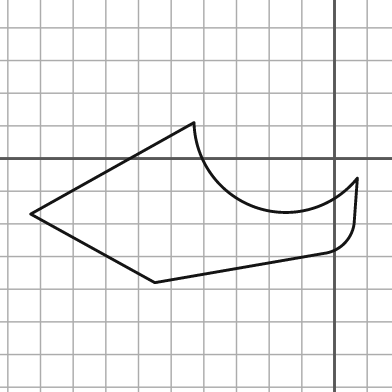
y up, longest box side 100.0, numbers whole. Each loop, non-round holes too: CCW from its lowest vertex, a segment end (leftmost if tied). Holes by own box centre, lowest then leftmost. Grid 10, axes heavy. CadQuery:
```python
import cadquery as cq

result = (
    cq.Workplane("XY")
    .moveTo(-55.0, -38.0)
    .lineTo(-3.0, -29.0)
    .threePointArc((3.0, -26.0), (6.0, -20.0))
    .lineTo(7.0, -6.0)
    .threePointArc((-24.0, -15.0), (-43.0, 11.0))
    .lineTo(-93.0, -17.0)
    .close()
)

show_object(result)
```